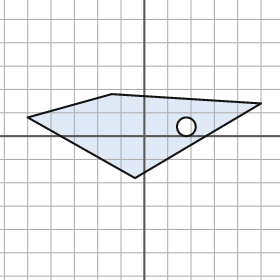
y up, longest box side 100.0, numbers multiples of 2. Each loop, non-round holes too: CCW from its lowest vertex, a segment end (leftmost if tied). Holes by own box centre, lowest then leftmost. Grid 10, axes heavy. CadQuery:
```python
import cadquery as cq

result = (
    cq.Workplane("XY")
    .moveTo(-4.0, -18.0)
    .lineTo(50.0, 14.0)
    .lineTo(-14.0, 18.0)
    .lineTo(-50.0, 8.0)
    .close()
    .moveTo(18.0, 4.0)
    .circle(4.0)
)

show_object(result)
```